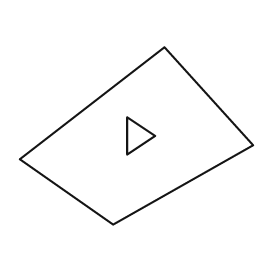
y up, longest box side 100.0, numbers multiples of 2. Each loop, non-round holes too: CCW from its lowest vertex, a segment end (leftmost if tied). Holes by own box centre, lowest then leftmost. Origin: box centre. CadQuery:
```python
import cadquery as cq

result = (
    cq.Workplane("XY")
    .moveTo(-10.0, -38.0)
    .lineTo(50.0, -4.0)
    .lineTo(12.0, 38.0)
    .lineTo(-50.0, -10.0)
    .close()
    .moveTo(-4.0, -8.0)
    .lineTo(8.0, 0.0)
    .lineTo(-4.0, 8.0)
    .close()
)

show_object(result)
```